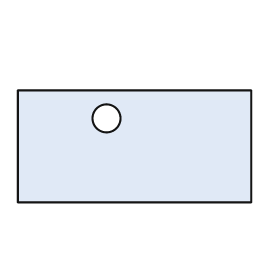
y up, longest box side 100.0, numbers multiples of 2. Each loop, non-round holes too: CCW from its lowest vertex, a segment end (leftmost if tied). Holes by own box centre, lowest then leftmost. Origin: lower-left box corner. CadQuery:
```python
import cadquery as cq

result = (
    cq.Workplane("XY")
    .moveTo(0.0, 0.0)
    .lineTo(100.0, 0.0)
    .lineTo(100.0, 48.0)
    .lineTo(0.0, 48.0)
    .close()
    .moveTo(38.0, 36.0)
    .circle(6.0)
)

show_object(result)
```